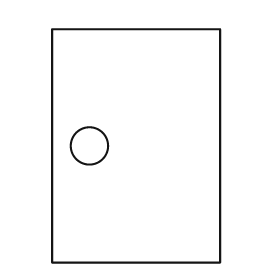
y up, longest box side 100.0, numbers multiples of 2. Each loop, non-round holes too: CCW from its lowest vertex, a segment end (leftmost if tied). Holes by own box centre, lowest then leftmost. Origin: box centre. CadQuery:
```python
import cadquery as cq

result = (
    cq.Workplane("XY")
    .moveTo(-36.0, -50.0)
    .lineTo(36.0, -50.0)
    .lineTo(36.0, 50.0)
    .lineTo(-36.0, 50.0)
    .close()
    .moveTo(-20.0, 0.0)
    .circle(8.0)
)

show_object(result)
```